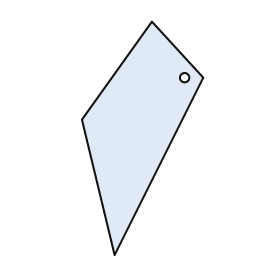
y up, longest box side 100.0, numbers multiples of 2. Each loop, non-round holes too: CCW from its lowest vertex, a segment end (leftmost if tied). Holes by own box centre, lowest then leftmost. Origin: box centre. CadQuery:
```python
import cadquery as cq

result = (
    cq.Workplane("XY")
    .moveTo(-12.0, -50.0)
    .lineTo(26.0, 26.0)
    .lineTo(4.0, 50.0)
    .lineTo(-26.0, 8.0)
    .close()
    .moveTo(18.0, 26.0)
    .circle(2.0)
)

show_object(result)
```